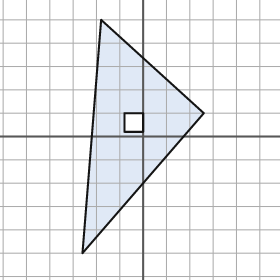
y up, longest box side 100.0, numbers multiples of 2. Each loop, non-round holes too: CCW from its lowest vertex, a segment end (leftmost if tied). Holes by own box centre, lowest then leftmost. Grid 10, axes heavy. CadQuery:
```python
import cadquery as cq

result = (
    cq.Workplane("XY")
    .moveTo(-26.0, -50.0)
    .lineTo(26.0, 10.0)
    .lineTo(-18.0, 50.0)
    .close()
    .moveTo(-8.0, 2.0)
    .lineTo(0.0, 2.0)
    .lineTo(0.0, 10.0)
    .lineTo(-8.0, 10.0)
    .close()
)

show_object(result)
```